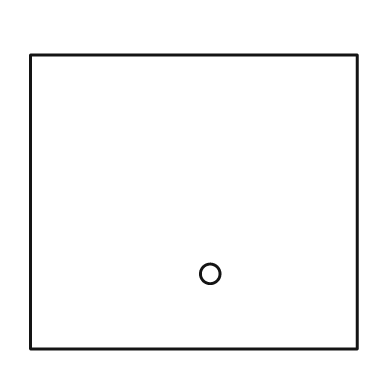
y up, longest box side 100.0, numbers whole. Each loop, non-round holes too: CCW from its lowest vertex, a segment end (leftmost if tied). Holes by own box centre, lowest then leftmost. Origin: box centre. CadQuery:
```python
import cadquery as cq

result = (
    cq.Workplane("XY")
    .moveTo(-50.0, -45.0)
    .lineTo(50.0, -45.0)
    .lineTo(50.0, 45.0)
    .lineTo(-50.0, 45.0)
    .close()
    .moveTo(5.0, -22.0)
    .circle(3.0)
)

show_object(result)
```